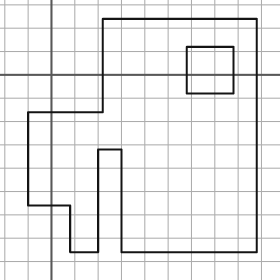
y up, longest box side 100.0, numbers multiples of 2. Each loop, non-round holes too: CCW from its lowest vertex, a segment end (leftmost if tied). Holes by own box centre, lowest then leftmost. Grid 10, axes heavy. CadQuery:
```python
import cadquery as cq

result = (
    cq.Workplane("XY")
    .moveTo(8.0, -76.0)
    .lineTo(20.0, -76.0)
    .lineTo(20.0, -32.0)
    .lineTo(30.0, -32.0)
    .lineTo(30.0, -76.0)
    .lineTo(88.0, -76.0)
    .lineTo(88.0, 24.0)
    .lineTo(22.0, 24.0)
    .lineTo(22.0, -16.0)
    .lineTo(-10.0, -16.0)
    .lineTo(-10.0, -56.0)
    .lineTo(8.0, -56.0)
    .close()
    .moveTo(58.0, -8.0)
    .lineTo(78.0, -8.0)
    .lineTo(78.0, 12.0)
    .lineTo(58.0, 12.0)
    .close()
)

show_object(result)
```